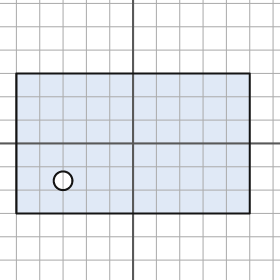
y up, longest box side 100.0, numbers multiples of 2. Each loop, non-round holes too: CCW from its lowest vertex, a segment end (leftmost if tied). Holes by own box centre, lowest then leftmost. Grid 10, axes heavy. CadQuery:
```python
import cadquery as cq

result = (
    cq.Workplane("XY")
    .moveTo(-50.0, -30.0)
    .lineTo(50.0, -30.0)
    .lineTo(50.0, 30.0)
    .lineTo(-50.0, 30.0)
    .close()
    .moveTo(-30.0, -16.0)
    .circle(4.0)
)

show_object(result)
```